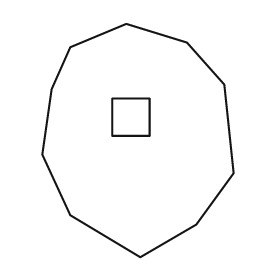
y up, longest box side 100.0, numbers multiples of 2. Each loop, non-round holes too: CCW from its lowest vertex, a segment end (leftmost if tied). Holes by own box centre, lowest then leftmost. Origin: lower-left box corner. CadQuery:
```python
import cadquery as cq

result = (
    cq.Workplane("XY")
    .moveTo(42.0, 0.0)
    .lineTo(66.0, 14.0)
    .lineTo(82.0, 36.0)
    .lineTo(78.0, 74.0)
    .lineTo(62.0, 92.0)
    .lineTo(36.0, 100.0)
    .lineTo(12.0, 90.0)
    .lineTo(4.0, 72.0)
    .lineTo(0.0, 44.0)
    .lineTo(12.0, 18.0)
    .close()
    .moveTo(30.0, 52.0)
    .lineTo(46.0, 52.0)
    .lineTo(46.0, 68.0)
    .lineTo(30.0, 68.0)
    .close()
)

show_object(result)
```